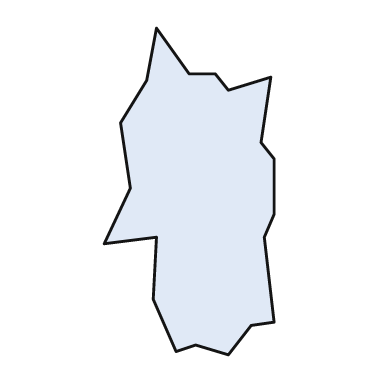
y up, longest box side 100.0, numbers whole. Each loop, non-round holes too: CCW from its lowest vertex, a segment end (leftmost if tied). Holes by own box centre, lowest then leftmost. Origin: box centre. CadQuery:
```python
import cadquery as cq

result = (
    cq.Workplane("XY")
    .moveTo(12.0, -50.0)
    .lineTo(19.0, -41.0)
    .lineTo(26.0, -40.0)
    .lineTo(23.0, -14.0)
    .lineTo(26.0, -7.0)
    .lineTo(26.0, 10.0)
    .lineTo(22.0, 15.0)
    .lineTo(25.0, 35.0)
    .lineTo(12.0, 31.0)
    .lineTo(8.0, 36.0)
    .lineTo(0.0, 36.0)
    .lineTo(-10.0, 50.0)
    .lineTo(-13.0, 34.0)
    .lineTo(-21.0, 21.0)
    .lineTo(-18.0, 1.0)
    .lineTo(-26.0, -16.0)
    .lineTo(-10.0, -14.0)
    .lineTo(-11.0, -33.0)
    .lineTo(-4.0, -49.0)
    .lineTo(2.0, -47.0)
    .close()
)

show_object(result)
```